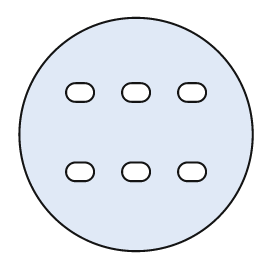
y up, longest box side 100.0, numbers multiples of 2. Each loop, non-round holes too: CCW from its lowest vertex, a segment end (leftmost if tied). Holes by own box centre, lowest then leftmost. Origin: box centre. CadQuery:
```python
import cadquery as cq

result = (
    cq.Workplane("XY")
    .moveTo(0.0, 0.0)
    .circle(50.0)
    .moveTo(-26.0, -20.0)
    .lineTo(-22.0, -20.0)
    .threePointArc((-18.0, -16.0), (-22.0, -12.0))
    .lineTo(-26.0, -12.0)
    .threePointArc((-30.0, -16.0), (-26.0, -20.0))
    .close()
    .moveTo(-2.0, -20.0)
    .lineTo(2.0, -20.0)
    .threePointArc((6.0, -16.0), (2.0, -12.0))
    .lineTo(-2.0, -12.0)
    .threePointArc((-6.0, -16.0), (-2.0, -20.0))
    .close()
    .moveTo(22.0, -20.0)
    .lineTo(26.0, -20.0)
    .threePointArc((30.0, -16.0), (26.0, -12.0))
    .lineTo(22.0, -12.0)
    .threePointArc((18.0, -16.0), (22.0, -20.0))
    .close()
    .moveTo(-26.0, 14.0)
    .lineTo(-22.0, 14.0)
    .threePointArc((-18.0, 18.0), (-22.0, 22.0))
    .lineTo(-26.0, 22.0)
    .threePointArc((-30.0, 18.0), (-26.0, 14.0))
    .close()
    .moveTo(-2.0, 14.0)
    .lineTo(2.0, 14.0)
    .threePointArc((6.0, 18.0), (2.0, 22.0))
    .lineTo(-2.0, 22.0)
    .threePointArc((-6.0, 18.0), (-2.0, 14.0))
    .close()
    .moveTo(22.0, 14.0)
    .lineTo(26.0, 14.0)
    .threePointArc((30.0, 18.0), (26.0, 22.0))
    .lineTo(22.0, 22.0)
    .threePointArc((18.0, 18.0), (22.0, 14.0))
    .close()
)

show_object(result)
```